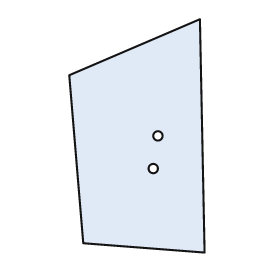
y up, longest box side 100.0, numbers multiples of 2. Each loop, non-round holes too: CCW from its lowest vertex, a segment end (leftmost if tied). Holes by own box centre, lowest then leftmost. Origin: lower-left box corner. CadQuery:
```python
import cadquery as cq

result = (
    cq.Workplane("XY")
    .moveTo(58.0, 0.0)
    .lineTo(56.0, 100.0)
    .lineTo(0.0, 76.0)
    .lineTo(6.0, 4.0)
    .close()
    .moveTo(36.0, 36.0)
    .circle(2.0)
    .moveTo(38.0, 50.0)
    .circle(2.0)
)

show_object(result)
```